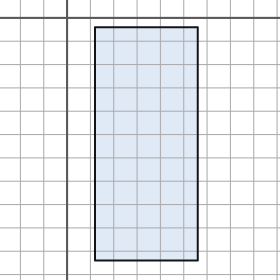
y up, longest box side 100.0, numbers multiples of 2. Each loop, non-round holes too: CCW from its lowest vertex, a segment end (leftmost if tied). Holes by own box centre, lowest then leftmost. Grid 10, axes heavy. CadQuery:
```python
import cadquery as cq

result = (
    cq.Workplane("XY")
    .moveTo(12.0, -104.0)
    .lineTo(56.0, -104.0)
    .lineTo(56.0, -4.0)
    .lineTo(12.0, -4.0)
    .close()
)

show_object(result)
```